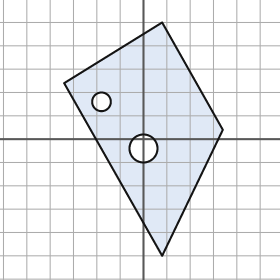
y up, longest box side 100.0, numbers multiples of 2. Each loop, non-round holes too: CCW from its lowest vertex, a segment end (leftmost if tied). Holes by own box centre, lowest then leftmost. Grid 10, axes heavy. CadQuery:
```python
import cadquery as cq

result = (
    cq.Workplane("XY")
    .moveTo(8.0, -50.0)
    .lineTo(34.0, 4.0)
    .lineTo(8.0, 50.0)
    .lineTo(-34.0, 24.0)
    .close()
    .moveTo(0.0, -4.0)
    .circle(6.0)
    .moveTo(-18.0, 16.0)
    .circle(4.0)
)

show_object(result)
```